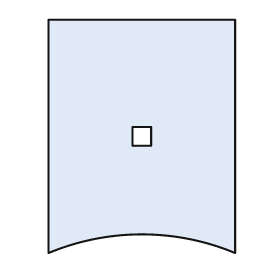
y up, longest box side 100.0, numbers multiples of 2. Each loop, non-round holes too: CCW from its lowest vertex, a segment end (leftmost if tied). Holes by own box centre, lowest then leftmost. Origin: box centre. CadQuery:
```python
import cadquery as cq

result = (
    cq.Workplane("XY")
    .moveTo(-40.0, -50.0)
    .threePointArc((0.0, -42.0), (40.0, -50.0))
    .lineTo(40.0, 50.0)
    .lineTo(-40.0, 50.0)
    .close()
    .moveTo(-4.0, -4.0)
    .lineTo(4.0, -4.0)
    .lineTo(4.0, 4.0)
    .lineTo(-4.0, 4.0)
    .close()
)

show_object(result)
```